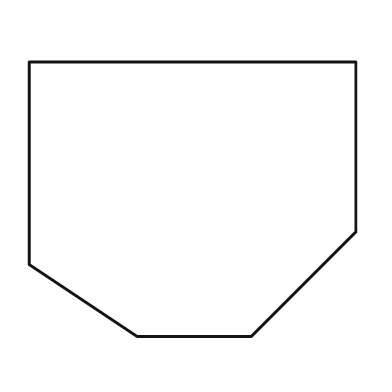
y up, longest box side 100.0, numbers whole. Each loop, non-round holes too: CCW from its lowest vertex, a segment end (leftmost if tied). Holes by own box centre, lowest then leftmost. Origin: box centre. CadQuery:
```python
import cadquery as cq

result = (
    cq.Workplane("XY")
    .moveTo(-17.0, -42.0)
    .lineTo(18.0, -42.0)
    .lineTo(50.0, -10.0)
    .lineTo(50.0, 42.0)
    .lineTo(-50.0, 42.0)
    .lineTo(-50.0, -20.0)
    .close()
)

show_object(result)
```